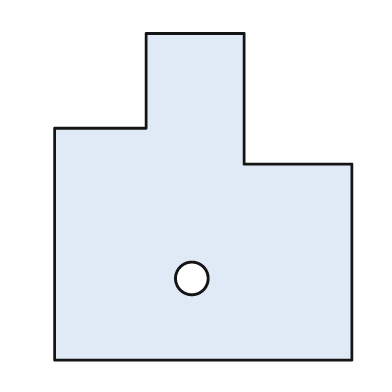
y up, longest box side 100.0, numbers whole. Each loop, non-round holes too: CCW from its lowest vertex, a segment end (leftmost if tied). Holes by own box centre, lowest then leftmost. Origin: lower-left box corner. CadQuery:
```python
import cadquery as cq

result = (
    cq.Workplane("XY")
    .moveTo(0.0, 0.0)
    .lineTo(91.0, 0.0)
    .lineTo(91.0, 60.0)
    .lineTo(58.0, 60.0)
    .lineTo(58.0, 100.0)
    .lineTo(28.0, 100.0)
    .lineTo(28.0, 71.0)
    .lineTo(0.0, 71.0)
    .close()
    .moveTo(42.0, 25.0)
    .circle(5.0)
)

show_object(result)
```